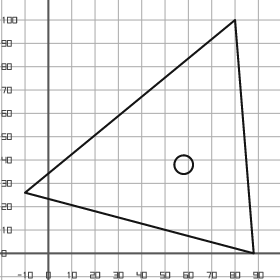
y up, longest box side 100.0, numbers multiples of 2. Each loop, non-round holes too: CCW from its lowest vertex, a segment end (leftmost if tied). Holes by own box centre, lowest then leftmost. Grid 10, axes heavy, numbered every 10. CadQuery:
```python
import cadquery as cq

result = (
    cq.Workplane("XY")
    .moveTo(88.0, 0.0)
    .lineTo(80.0, 100.0)
    .lineTo(-10.0, 26.0)
    .close()
    .moveTo(58.0, 38.0)
    .circle(4.0)
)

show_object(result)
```